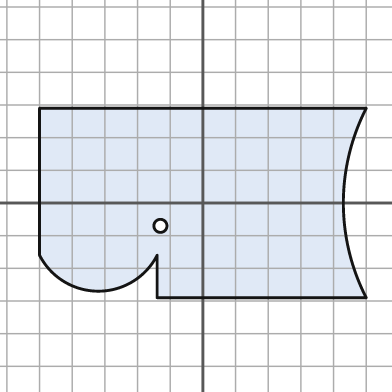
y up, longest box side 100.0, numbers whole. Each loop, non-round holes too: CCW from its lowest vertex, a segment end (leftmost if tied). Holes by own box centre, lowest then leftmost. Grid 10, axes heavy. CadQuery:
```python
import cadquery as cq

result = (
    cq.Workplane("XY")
    .moveTo(-14.0, -29.0)
    .lineTo(50.0, -29.0)
    .threePointArc((43.0, 0.0), (50.0, 29.0))
    .lineTo(-50.0, 29.0)
    .lineTo(-50.0, -16.0)
    .threePointArc((-32.0, -27.0), (-14.0, -16.0))
    .close()
    .moveTo(-13.0, -7.0)
    .circle(2.0)
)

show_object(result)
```